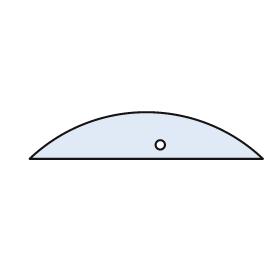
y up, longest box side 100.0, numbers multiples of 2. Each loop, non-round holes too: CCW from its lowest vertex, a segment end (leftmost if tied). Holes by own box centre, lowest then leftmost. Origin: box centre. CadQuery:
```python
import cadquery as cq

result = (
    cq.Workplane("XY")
    .moveTo(-50.0, -10.0)
    .lineTo(50.0, -10.0)
    .threePointArc((0.0, 10.0), (-50.0, -10.0))
    .close()
    .moveTo(6.0, -4.0)
    .circle(2.0)
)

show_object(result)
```